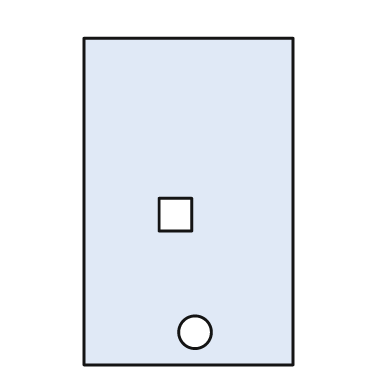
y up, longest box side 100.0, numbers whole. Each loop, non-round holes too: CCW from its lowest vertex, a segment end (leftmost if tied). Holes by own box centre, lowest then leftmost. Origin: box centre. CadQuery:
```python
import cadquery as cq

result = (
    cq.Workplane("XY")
    .moveTo(-32.0, -50.0)
    .lineTo(32.0, -50.0)
    .lineTo(32.0, 50.0)
    .lineTo(-32.0, 50.0)
    .close()
    .moveTo(2.0, -40.0)
    .circle(5.0)
    .moveTo(-9.0, -9.0)
    .lineTo(1.0, -9.0)
    .lineTo(1.0, 1.0)
    .lineTo(-9.0, 1.0)
    .close()
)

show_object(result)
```